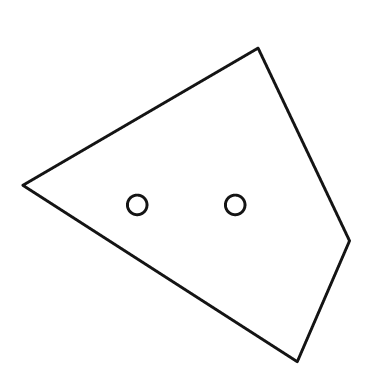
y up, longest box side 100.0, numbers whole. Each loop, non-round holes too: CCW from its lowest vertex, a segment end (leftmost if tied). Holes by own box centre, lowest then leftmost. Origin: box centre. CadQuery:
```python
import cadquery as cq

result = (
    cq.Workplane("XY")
    .moveTo(34.0, -48.0)
    .lineTo(50.0, -11.0)
    .lineTo(22.0, 48.0)
    .lineTo(-50.0, 6.0)
    .close()
    .moveTo(-15.0, 0.0)
    .circle(3.0)
    .moveTo(15.0, 0.0)
    .circle(3.0)
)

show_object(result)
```